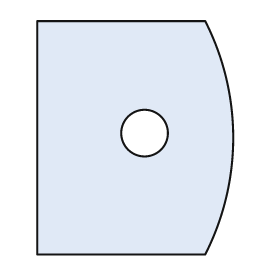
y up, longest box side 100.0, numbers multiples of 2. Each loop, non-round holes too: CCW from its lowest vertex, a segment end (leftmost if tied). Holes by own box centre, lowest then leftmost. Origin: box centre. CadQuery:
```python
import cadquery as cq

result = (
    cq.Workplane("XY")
    .moveTo(-42.0, -50.0)
    .lineTo(30.0, -50.0)
    .threePointArc((42.0, 0.0), (30.0, 50.0))
    .lineTo(-42.0, 50.0)
    .close()
    .moveTo(4.0, 2.0)
    .circle(10.0)
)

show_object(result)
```